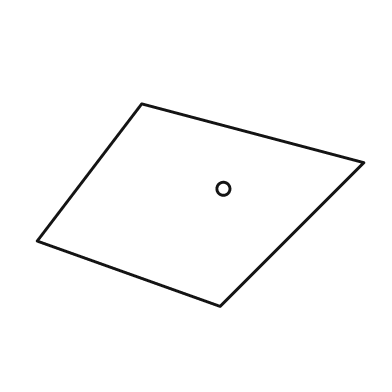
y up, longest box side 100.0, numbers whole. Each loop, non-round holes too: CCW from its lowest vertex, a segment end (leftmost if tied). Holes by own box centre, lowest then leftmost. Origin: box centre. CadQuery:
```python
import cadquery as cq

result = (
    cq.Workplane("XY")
    .moveTo(6.0, -31.0)
    .lineTo(50.0, 13.0)
    .lineTo(-18.0, 31.0)
    .lineTo(-50.0, -11.0)
    .close()
    .moveTo(7.0, 5.0)
    .circle(2.0)
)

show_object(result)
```